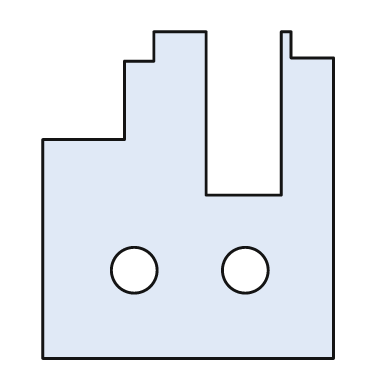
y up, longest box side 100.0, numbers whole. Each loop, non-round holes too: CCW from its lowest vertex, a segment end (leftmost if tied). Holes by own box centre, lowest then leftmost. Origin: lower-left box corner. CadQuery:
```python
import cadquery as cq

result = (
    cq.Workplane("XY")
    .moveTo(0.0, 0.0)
    .lineTo(89.0, 0.0)
    .lineTo(89.0, 92.0)
    .lineTo(76.0, 92.0)
    .lineTo(76.0, 100.0)
    .lineTo(73.0, 100.0)
    .lineTo(73.0, 50.0)
    .lineTo(50.0, 50.0)
    .lineTo(50.0, 100.0)
    .lineTo(34.0, 100.0)
    .lineTo(34.0, 91.0)
    .lineTo(25.0, 91.0)
    .lineTo(25.0, 67.0)
    .lineTo(0.0, 67.0)
    .close()
    .moveTo(28.0, 27.0)
    .circle(7.0)
    .moveTo(62.0, 27.0)
    .circle(7.0)
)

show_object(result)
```